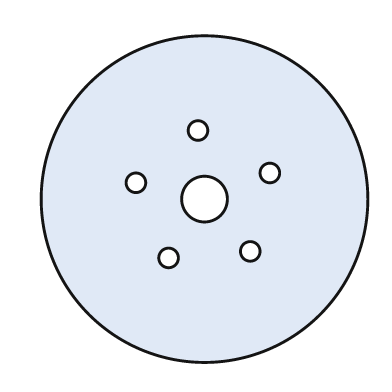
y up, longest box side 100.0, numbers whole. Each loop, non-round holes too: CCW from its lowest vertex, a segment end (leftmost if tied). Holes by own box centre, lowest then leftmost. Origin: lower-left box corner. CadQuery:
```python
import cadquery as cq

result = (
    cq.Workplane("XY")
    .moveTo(50.0, 50.0)
    .circle(50.0)
    .moveTo(39.0, 32.0)
    .circle(3.0)
    .moveTo(64.0, 34.0)
    .circle(3.0)
    .moveTo(50.0, 50.0)
    .circle(7.0)
    .moveTo(29.0, 55.0)
    .circle(3.0)
    .moveTo(70.0, 58.0)
    .circle(3.0)
    .moveTo(48.0, 71.0)
    .circle(3.0)
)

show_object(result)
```